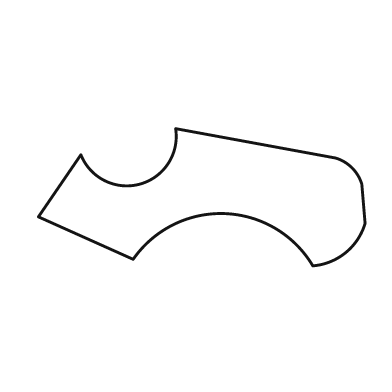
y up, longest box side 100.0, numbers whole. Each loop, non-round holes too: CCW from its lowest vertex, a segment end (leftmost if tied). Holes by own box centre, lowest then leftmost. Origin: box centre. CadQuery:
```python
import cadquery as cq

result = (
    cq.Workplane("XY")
    .moveTo(34.0, -21.0)
    .threePointArc((44.0, -17.0), (50.0, -8.0))
    .lineTo(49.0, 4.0)
    .threePointArc((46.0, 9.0), (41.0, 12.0))
    .lineTo(-8.0, 21.0)
    .threePointArc((-19.0, 4.0), (-37.0, 13.0))
    .lineTo(-50.0, -6.0)
    .lineTo(-21.0, -19.0)
    .threePointArc((7.0, -5.0), (34.0, -21.0))
    .close()
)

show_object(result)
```